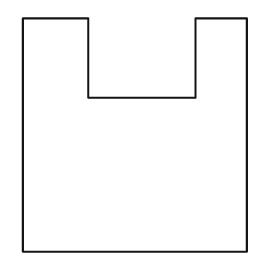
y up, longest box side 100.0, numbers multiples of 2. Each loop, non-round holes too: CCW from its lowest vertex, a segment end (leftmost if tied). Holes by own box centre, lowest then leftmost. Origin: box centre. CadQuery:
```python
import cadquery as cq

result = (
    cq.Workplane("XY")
    .moveTo(-48.0, -50.0)
    .lineTo(48.0, -50.0)
    .lineTo(48.0, 50.0)
    .lineTo(26.0, 50.0)
    .lineTo(26.0, 16.0)
    .lineTo(-20.0, 16.0)
    .lineTo(-20.0, 50.0)
    .lineTo(-48.0, 50.0)
    .close()
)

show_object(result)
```